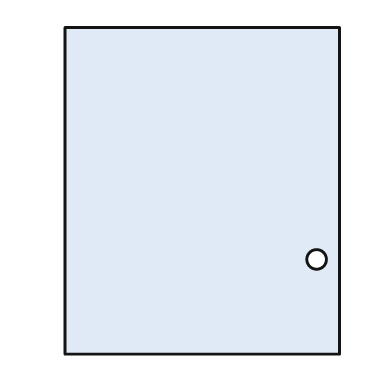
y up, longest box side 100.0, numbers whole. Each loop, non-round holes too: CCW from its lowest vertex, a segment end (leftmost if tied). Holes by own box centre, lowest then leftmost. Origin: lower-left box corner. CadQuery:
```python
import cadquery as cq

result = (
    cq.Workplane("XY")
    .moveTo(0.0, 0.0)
    .lineTo(84.0, 0.0)
    .lineTo(84.0, 100.0)
    .lineTo(0.0, 100.0)
    .close()
    .moveTo(77.0, 29.0)
    .circle(3.0)
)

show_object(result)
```